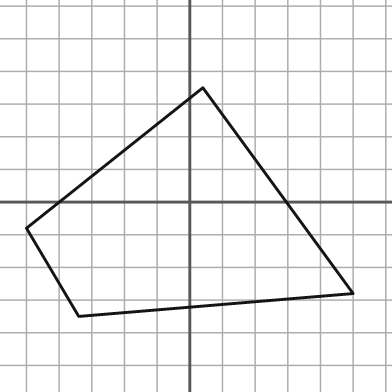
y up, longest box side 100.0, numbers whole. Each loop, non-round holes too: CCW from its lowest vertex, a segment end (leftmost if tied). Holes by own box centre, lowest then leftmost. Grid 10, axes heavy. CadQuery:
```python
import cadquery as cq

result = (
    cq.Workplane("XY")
    .moveTo(-34.0, -35.0)
    .lineTo(50.0, -28.0)
    .lineTo(4.0, 35.0)
    .lineTo(-50.0, -8.0)
    .close()
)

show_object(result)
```